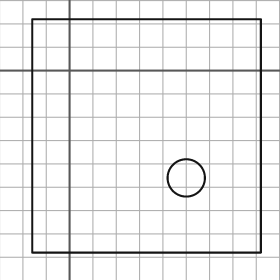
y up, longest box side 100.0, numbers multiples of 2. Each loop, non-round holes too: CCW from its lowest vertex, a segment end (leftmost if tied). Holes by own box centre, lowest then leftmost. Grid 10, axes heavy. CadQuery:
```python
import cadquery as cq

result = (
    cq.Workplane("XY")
    .moveTo(-16.0, -78.0)
    .lineTo(82.0, -78.0)
    .lineTo(82.0, 22.0)
    .lineTo(-16.0, 22.0)
    .close()
    .moveTo(50.0, -46.0)
    .circle(8.0)
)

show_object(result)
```